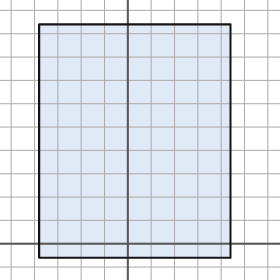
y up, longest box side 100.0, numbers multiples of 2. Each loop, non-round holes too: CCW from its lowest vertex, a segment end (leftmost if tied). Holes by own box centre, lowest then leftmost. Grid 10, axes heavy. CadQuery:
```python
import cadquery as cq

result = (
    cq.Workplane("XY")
    .moveTo(-38.0, -6.0)
    .lineTo(44.0, -6.0)
    .lineTo(44.0, 94.0)
    .lineTo(-38.0, 94.0)
    .close()
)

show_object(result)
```